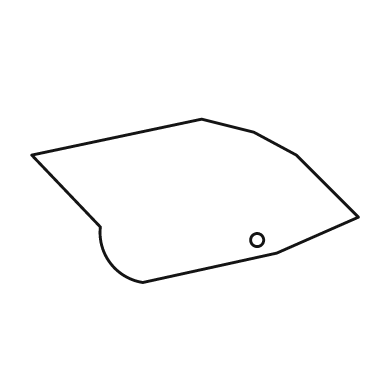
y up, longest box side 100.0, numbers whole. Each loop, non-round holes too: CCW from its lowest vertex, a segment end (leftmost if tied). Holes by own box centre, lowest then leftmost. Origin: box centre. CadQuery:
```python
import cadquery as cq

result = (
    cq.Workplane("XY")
    .moveTo(-16.0, -25.0)
    .lineTo(25.0, -16.0)
    .lineTo(50.0, -5.0)
    .lineTo(31.0, 14.0)
    .lineTo(18.0, 21.0)
    .lineTo(2.0, 25.0)
    .lineTo(-50.0, 14.0)
    .lineTo(-29.0, -8.0)
    .threePointArc((-26.0, -19.0), (-16.0, -25.0))
    .close()
    .moveTo(19.0, -12.0)
    .circle(2.0)
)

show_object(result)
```